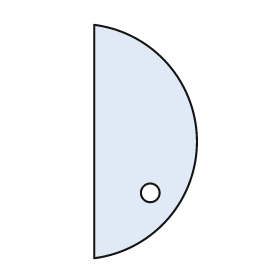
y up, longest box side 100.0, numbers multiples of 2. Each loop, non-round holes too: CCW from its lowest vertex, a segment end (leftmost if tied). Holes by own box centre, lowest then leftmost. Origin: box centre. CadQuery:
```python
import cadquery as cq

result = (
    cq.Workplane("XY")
    .moveTo(-22.0, -50.0)
    .threePointArc((22.0, 0.0), (-22.0, 50.0))
    .close()
    .moveTo(2.0, -22.0)
    .circle(4.0)
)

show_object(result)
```